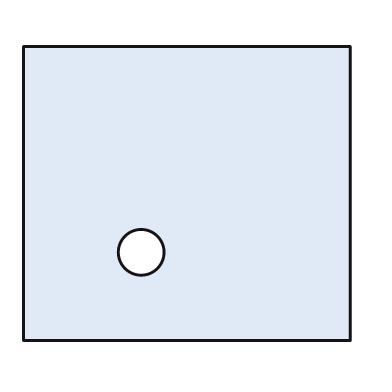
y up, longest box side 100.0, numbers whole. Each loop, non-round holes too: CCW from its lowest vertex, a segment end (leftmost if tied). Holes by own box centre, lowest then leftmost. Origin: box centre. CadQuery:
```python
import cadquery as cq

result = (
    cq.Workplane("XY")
    .moveTo(-50.0, -45.0)
    .lineTo(50.0, -45.0)
    .lineTo(50.0, 45.0)
    .lineTo(-50.0, 45.0)
    .close()
    .moveTo(-14.0, -18.0)
    .circle(7.0)
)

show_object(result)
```